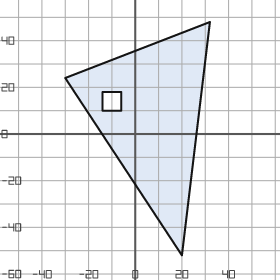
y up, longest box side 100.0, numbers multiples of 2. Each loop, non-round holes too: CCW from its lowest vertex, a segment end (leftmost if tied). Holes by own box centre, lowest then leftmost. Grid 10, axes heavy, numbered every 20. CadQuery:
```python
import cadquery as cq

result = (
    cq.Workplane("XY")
    .moveTo(20.0, -52.0)
    .lineTo(32.0, 48.0)
    .lineTo(-30.0, 24.0)
    .close()
    .moveTo(-14.0, 10.0)
    .lineTo(-6.0, 10.0)
    .lineTo(-6.0, 18.0)
    .lineTo(-14.0, 18.0)
    .close()
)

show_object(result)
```